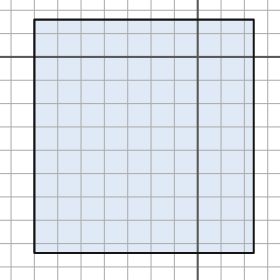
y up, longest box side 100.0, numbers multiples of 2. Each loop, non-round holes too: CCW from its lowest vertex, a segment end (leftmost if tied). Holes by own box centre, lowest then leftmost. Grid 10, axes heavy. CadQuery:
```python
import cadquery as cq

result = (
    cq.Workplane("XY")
    .moveTo(-70.0, -84.0)
    .lineTo(24.0, -84.0)
    .lineTo(24.0, 16.0)
    .lineTo(-70.0, 16.0)
    .close()
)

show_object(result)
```